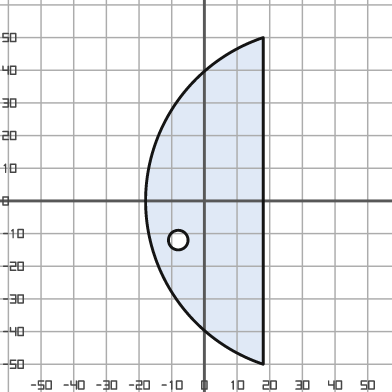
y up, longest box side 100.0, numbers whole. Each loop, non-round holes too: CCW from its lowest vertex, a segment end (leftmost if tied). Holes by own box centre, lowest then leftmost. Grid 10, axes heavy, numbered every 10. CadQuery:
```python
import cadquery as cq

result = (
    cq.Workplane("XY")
    .moveTo(18.0, -50.0)
    .lineTo(18.0, 50.0)
    .threePointArc((-18.0, 0.0), (18.0, -50.0))
    .close()
    .moveTo(-8.0, -12.0)
    .circle(3.0)
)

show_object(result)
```